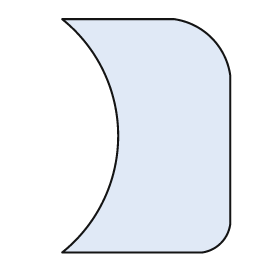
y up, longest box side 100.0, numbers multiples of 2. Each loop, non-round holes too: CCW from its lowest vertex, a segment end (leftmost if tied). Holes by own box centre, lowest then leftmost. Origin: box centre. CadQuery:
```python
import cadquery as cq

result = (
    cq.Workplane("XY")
    .moveTo(-36.0, -50.0)
    .lineTo(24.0, -50.0)
    .threePointArc((32.0, -46.0), (36.0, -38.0))
    .lineTo(36.0, 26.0)
    .threePointArc((28.0, 42.0), (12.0, 50.0))
    .lineTo(-36.0, 50.0)
    .threePointArc((-12.0, 0.0), (-36.0, -50.0))
    .close()
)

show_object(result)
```